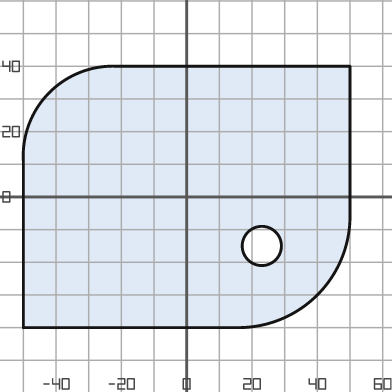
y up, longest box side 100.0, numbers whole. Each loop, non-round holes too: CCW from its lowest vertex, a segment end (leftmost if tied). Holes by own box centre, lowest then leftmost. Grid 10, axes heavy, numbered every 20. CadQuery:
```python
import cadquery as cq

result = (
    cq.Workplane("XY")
    .moveTo(-50.0, -40.0)
    .lineTo(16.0, -40.0)
    .threePointArc((40.0, -30.0), (50.0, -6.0))
    .lineTo(50.0, 40.0)
    .lineTo(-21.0, 40.0)
    .threePointArc((-42.0, 32.0), (-50.0, 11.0))
    .close()
    .moveTo(23.0, -15.0)
    .circle(6.0)
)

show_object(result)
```